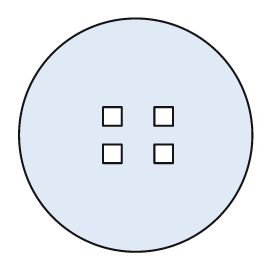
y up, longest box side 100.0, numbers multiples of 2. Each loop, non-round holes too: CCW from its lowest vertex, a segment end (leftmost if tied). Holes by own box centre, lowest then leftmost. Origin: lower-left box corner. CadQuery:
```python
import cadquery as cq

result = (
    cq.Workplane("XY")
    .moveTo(50.0, 50.0)
    .circle(50.0)
    .moveTo(36.0, 38.0)
    .lineTo(44.0, 38.0)
    .lineTo(44.0, 46.0)
    .lineTo(36.0, 46.0)
    .close()
    .moveTo(58.0, 38.0)
    .lineTo(66.0, 38.0)
    .lineTo(66.0, 46.0)
    .lineTo(58.0, 46.0)
    .close()
    .moveTo(36.0, 54.0)
    .lineTo(44.0, 54.0)
    .lineTo(44.0, 62.0)
    .lineTo(36.0, 62.0)
    .close()
    .moveTo(58.0, 54.0)
    .lineTo(66.0, 54.0)
    .lineTo(66.0, 62.0)
    .lineTo(58.0, 62.0)
    .close()
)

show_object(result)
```